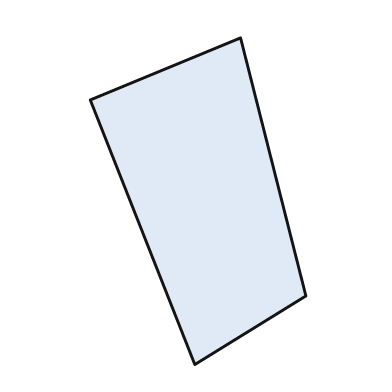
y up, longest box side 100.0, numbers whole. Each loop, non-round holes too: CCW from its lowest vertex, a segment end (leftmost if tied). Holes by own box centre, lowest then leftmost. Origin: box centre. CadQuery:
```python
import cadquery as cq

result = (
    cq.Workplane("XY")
    .moveTo(-1.0, -50.0)
    .lineTo(33.0, -29.0)
    .lineTo(13.0, 50.0)
    .lineTo(-33.0, 31.0)
    .close()
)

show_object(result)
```